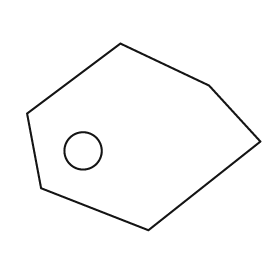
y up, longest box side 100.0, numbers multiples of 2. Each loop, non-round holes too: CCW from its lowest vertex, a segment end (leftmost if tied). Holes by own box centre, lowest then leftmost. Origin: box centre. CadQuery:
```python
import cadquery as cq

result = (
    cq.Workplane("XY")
    .moveTo(2.0, -40.0)
    .lineTo(50.0, -2.0)
    .lineTo(28.0, 22.0)
    .lineTo(-10.0, 40.0)
    .lineTo(-50.0, 10.0)
    .lineTo(-44.0, -22.0)
    .close()
    .moveTo(-26.0, -6.0)
    .circle(8.0)
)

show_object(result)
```